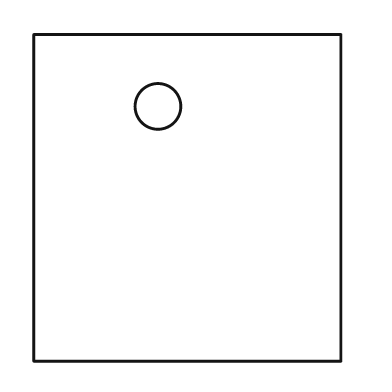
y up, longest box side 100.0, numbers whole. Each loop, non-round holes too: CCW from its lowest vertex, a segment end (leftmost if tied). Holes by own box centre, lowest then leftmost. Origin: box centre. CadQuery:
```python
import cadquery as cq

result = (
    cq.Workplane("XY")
    .moveTo(-47.0, -50.0)
    .lineTo(47.0, -50.0)
    .lineTo(47.0, 50.0)
    .lineTo(-47.0, 50.0)
    .close()
    .moveTo(-9.0, 28.0)
    .circle(7.0)
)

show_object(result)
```